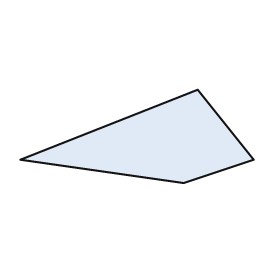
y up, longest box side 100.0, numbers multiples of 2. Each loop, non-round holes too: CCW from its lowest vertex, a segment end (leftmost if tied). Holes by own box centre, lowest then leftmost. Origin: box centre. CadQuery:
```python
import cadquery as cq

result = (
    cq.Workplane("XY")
    .moveTo(20.0, -20.0)
    .lineTo(50.0, -10.0)
    .lineTo(26.0, 20.0)
    .lineTo(-50.0, -10.0)
    .close()
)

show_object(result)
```